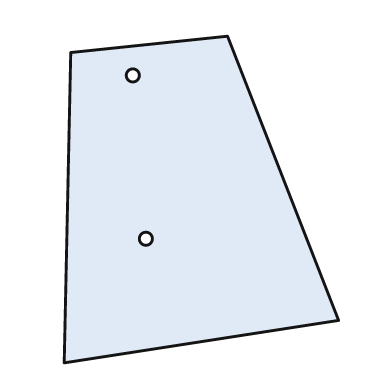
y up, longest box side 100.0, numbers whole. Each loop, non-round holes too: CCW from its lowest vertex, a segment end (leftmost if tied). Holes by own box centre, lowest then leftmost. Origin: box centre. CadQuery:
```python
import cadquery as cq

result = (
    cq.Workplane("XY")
    .moveTo(-42.0, -50.0)
    .lineTo(42.0, -37.0)
    .lineTo(8.0, 50.0)
    .lineTo(-40.0, 45.0)
    .close()
    .moveTo(-17.0, -12.0)
    .circle(2.0)
    .moveTo(-21.0, 38.0)
    .circle(2.0)
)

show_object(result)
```